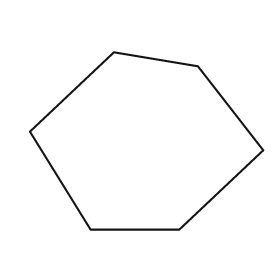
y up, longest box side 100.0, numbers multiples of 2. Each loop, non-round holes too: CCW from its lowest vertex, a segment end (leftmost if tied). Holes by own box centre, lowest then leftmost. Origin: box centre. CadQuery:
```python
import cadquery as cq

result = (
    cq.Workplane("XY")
    .moveTo(-24.0, -38.0)
    .lineTo(14.0, -38.0)
    .lineTo(50.0, -4.0)
    .lineTo(22.0, 32.0)
    .lineTo(-14.0, 38.0)
    .lineTo(-50.0, 4.0)
    .close()
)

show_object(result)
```